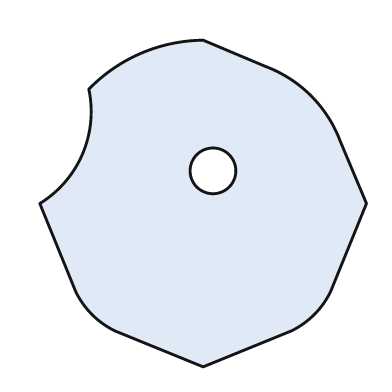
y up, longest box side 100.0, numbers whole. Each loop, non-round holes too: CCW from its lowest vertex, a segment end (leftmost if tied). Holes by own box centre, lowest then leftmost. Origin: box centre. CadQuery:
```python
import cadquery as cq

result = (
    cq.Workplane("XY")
    .moveTo(0.0, -50.0)
    .lineTo(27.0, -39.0)
    .threePointArc((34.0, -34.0), (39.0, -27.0))
    .lineTo(50.0, 0.0)
    .lineTo(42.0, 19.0)
    .threePointArc((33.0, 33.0), (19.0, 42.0))
    .lineTo(0.0, 50.0)
    .threePointArc((-19.0, 46.0), (-35.0, 35.0))
    .threePointArc((-37.0, 15.0), (-50.0, 0.0))
    .lineTo(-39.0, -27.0)
    .threePointArc((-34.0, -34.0), (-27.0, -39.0))
    .close()
    .moveTo(3.0, 10.0)
    .circle(7.0)
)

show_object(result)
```